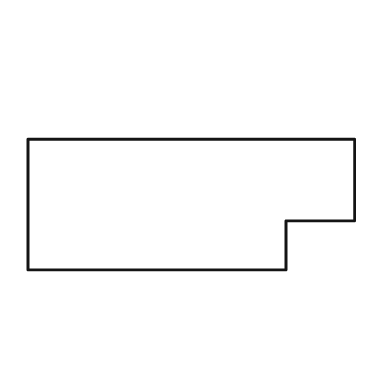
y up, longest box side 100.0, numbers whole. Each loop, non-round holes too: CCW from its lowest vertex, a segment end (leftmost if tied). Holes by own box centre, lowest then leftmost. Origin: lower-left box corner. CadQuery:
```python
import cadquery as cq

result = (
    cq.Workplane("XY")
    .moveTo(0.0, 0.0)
    .lineTo(79.0, 0.0)
    .lineTo(79.0, 15.0)
    .lineTo(100.0, 15.0)
    .lineTo(100.0, 40.0)
    .lineTo(0.0, 40.0)
    .close()
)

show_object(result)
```